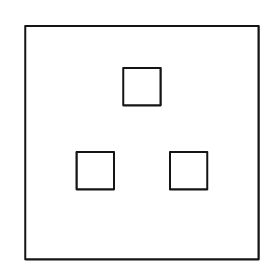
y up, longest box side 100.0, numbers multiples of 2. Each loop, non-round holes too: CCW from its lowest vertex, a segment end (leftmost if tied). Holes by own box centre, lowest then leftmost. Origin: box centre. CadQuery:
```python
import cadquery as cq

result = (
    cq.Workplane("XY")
    .moveTo(-50.0, -50.0)
    .lineTo(50.0, -50.0)
    .lineTo(50.0, 50.0)
    .lineTo(-50.0, 50.0)
    .close()
    .moveTo(-28.0, -20.0)
    .lineTo(-12.0, -20.0)
    .lineTo(-12.0, -4.0)
    .lineTo(-28.0, -4.0)
    .close()
    .moveTo(12.0, -20.0)
    .lineTo(28.0, -20.0)
    .lineTo(28.0, -4.0)
    .lineTo(12.0, -4.0)
    .close()
    .moveTo(-8.0, 16.0)
    .lineTo(8.0, 16.0)
    .lineTo(8.0, 32.0)
    .lineTo(-8.0, 32.0)
    .close()
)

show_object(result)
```